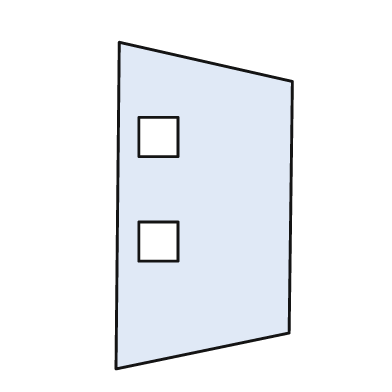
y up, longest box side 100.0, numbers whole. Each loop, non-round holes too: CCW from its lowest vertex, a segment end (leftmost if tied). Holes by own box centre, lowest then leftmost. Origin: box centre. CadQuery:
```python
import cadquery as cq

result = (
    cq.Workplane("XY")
    .moveTo(-27.0, -50.0)
    .lineTo(26.0, -39.0)
    .lineTo(27.0, 38.0)
    .lineTo(-26.0, 50.0)
    .close()
    .moveTo(-20.0, -17.0)
    .lineTo(-8.0, -17.0)
    .lineTo(-8.0, -5.0)
    .lineTo(-20.0, -5.0)
    .close()
    .moveTo(-20.0, 15.0)
    .lineTo(-8.0, 15.0)
    .lineTo(-8.0, 27.0)
    .lineTo(-20.0, 27.0)
    .close()
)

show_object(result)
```